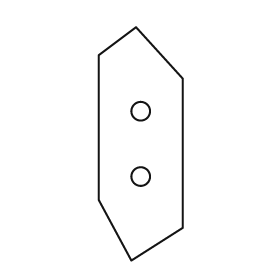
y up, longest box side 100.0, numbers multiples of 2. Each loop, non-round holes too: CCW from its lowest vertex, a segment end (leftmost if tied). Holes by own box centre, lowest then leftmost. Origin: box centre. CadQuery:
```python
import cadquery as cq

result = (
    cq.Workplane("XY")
    .moveTo(-4.0, -50.0)
    .lineTo(18.0, -36.0)
    .lineTo(18.0, 28.0)
    .lineTo(-2.0, 50.0)
    .lineTo(-18.0, 38.0)
    .lineTo(-18.0, -24.0)
    .close()
    .moveTo(0.0, -14.0)
    .circle(4.0)
    .moveTo(0.0, 14.0)
    .circle(4.0)
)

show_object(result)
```